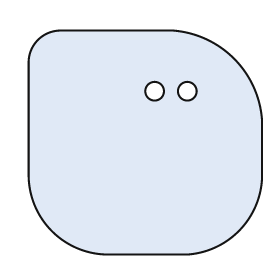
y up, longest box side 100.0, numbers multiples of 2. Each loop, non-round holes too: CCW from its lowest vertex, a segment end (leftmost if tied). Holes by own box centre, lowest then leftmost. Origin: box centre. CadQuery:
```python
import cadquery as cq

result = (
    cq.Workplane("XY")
    .moveTo(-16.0, -48.0)
    .lineTo(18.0, -48.0)
    .threePointArc((40.0, -38.0), (50.0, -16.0))
    .lineTo(50.0, 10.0)
    .threePointArc((38.0, 36.0), (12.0, 48.0))
    .lineTo(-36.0, 48.0)
    .threePointArc((-46.0, 44.0), (-50.0, 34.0))
    .lineTo(-50.0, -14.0)
    .threePointArc((-40.0, -38.0), (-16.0, -48.0))
    .close()
    .moveTo(4.0, 22.0)
    .circle(4.0)
    .moveTo(18.0, 22.0)
    .circle(4.0)
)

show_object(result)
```